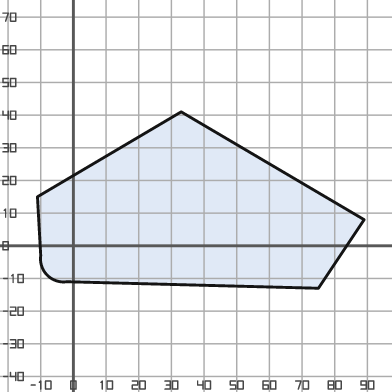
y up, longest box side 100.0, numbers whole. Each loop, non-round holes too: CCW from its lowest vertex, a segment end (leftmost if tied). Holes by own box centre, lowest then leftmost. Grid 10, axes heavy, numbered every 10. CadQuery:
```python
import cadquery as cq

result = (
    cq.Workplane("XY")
    .moveTo(75.0, -13.0)
    .lineTo(89.0, 8.0)
    .lineTo(33.0, 41.0)
    .lineTo(-11.0, 15.0)
    .lineTo(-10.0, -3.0)
    .threePointArc((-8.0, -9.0), (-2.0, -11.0))
    .close()
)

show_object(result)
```